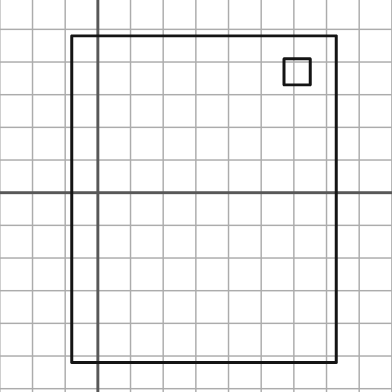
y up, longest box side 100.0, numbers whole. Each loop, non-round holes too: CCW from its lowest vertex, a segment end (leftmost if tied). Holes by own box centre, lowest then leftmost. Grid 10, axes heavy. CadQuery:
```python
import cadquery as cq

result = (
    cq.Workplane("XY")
    .moveTo(-8.0, -52.0)
    .lineTo(73.0, -52.0)
    .lineTo(73.0, 48.0)
    .lineTo(-8.0, 48.0)
    .close()
    .moveTo(57.0, 33.0)
    .lineTo(65.0, 33.0)
    .lineTo(65.0, 41.0)
    .lineTo(57.0, 41.0)
    .close()
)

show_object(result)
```